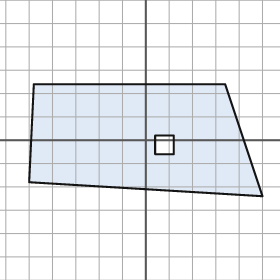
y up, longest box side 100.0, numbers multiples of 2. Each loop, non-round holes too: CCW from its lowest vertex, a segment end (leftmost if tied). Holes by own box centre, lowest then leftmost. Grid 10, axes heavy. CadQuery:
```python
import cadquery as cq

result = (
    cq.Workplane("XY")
    .moveTo(50.0, -24.0)
    .lineTo(34.0, 24.0)
    .lineTo(-48.0, 24.0)
    .lineTo(-50.0, -18.0)
    .close()
    .moveTo(4.0, -6.0)
    .lineTo(12.0, -6.0)
    .lineTo(12.0, 2.0)
    .lineTo(4.0, 2.0)
    .close()
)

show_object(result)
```